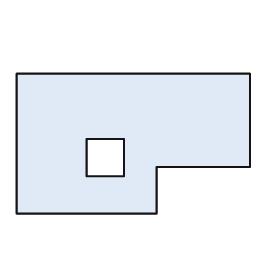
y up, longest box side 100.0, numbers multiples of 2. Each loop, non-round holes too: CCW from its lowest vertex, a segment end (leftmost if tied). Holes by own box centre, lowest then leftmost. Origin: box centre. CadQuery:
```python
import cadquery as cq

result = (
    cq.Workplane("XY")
    .moveTo(-50.0, -30.0)
    .lineTo(10.0, -30.0)
    .lineTo(10.0, -10.0)
    .lineTo(50.0, -10.0)
    .lineTo(50.0, 30.0)
    .lineTo(-50.0, 30.0)
    .close()
    .moveTo(-20.0, -14.0)
    .lineTo(-4.0, -14.0)
    .lineTo(-4.0, 2.0)
    .lineTo(-20.0, 2.0)
    .close()
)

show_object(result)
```